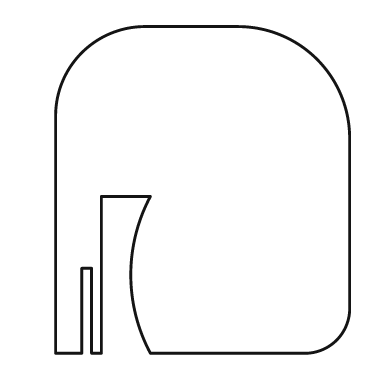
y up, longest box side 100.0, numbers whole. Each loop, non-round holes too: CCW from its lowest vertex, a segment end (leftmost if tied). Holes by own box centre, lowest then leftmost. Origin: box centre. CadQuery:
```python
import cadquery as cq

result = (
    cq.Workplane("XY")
    .moveTo(-45.0, -50.0)
    .lineTo(-37.0, -50.0)
    .lineTo(-37.0, -24.0)
    .lineTo(-34.0, -24.0)
    .lineTo(-34.0, -50.0)
    .lineTo(-31.0, -50.0)
    .lineTo(-31.0, -2.0)
    .lineTo(-16.0, -2.0)
    .threePointArc((-22.0, -26.0), (-16.0, -50.0))
    .lineTo(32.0, -50.0)
    .threePointArc((41.0, -46.0), (45.0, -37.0))
    .lineTo(45.0, 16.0)
    .threePointArc((35.0, 40.0), (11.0, 50.0))
    .lineTo(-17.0, 50.0)
    .threePointArc((-37.0, 42.0), (-45.0, 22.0))
    .close()
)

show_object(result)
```